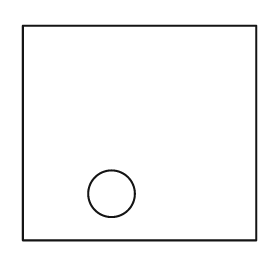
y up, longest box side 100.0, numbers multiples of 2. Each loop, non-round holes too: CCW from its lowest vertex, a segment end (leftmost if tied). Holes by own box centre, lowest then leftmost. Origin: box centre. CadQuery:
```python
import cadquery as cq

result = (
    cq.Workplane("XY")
    .moveTo(-50.0, -46.0)
    .lineTo(50.0, -46.0)
    .lineTo(50.0, 46.0)
    .lineTo(-50.0, 46.0)
    .close()
    .moveTo(-12.0, -26.0)
    .circle(10.0)
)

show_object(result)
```